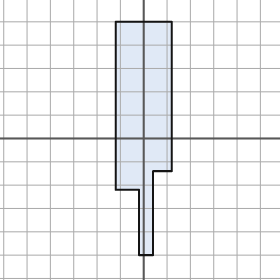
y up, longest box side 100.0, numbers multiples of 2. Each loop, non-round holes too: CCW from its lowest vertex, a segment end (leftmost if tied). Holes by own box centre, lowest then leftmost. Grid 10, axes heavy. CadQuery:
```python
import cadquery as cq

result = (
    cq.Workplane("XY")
    .moveTo(-2.0, -50.0)
    .lineTo(4.0, -50.0)
    .lineTo(4.0, -14.0)
    .lineTo(12.0, -14.0)
    .lineTo(12.0, 50.0)
    .lineTo(-12.0, 50.0)
    .lineTo(-12.0, -22.0)
    .lineTo(-2.0, -22.0)
    .close()
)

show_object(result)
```